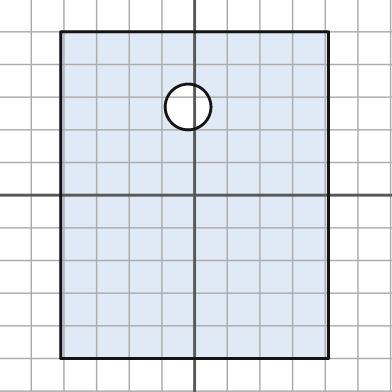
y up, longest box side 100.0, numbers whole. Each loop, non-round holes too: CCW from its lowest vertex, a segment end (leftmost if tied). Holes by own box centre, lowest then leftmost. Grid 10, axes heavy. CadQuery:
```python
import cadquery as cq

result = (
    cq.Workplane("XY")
    .moveTo(-41.0, -50.0)
    .lineTo(41.0, -50.0)
    .lineTo(41.0, 50.0)
    .lineTo(-41.0, 50.0)
    .close()
    .moveTo(-2.0, 27.0)
    .circle(7.0)
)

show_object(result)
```